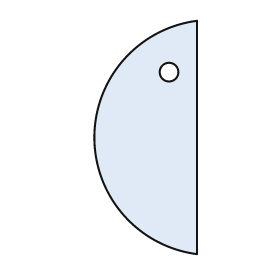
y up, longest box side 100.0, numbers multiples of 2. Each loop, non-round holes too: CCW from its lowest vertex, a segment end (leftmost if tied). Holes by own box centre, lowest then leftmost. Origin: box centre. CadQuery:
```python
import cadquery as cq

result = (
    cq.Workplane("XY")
    .moveTo(22.0, -50.0)
    .lineTo(22.0, 50.0)
    .threePointArc((-22.0, 0.0), (22.0, -50.0))
    .close()
    .moveTo(10.0, 28.0)
    .circle(4.0)
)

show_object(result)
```